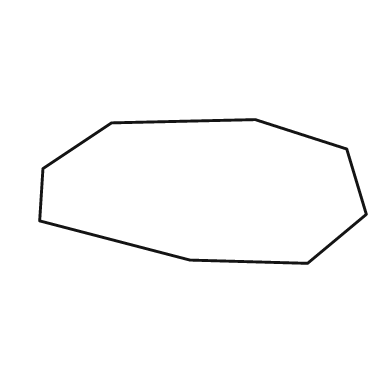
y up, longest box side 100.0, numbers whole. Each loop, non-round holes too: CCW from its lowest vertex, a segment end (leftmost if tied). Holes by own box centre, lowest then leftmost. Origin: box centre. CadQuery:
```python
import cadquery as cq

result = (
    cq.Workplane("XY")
    .moveTo(32.0, -22.0)
    .lineTo(50.0, -7.0)
    .lineTo(44.0, 13.0)
    .lineTo(16.0, 22.0)
    .lineTo(-28.0, 21.0)
    .lineTo(-49.0, 7.0)
    .lineTo(-50.0, -9.0)
    .lineTo(-4.0, -21.0)
    .close()
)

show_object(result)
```